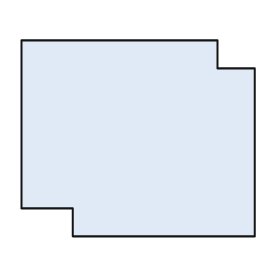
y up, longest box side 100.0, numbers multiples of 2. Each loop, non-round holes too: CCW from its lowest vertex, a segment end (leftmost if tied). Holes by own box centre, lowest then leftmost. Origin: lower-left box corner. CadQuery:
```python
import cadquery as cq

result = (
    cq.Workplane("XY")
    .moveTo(22.0, 0.0)
    .lineTo(100.0, 0.0)
    .lineTo(100.0, 72.0)
    .lineTo(84.0, 72.0)
    .lineTo(84.0, 84.0)
    .lineTo(0.0, 84.0)
    .lineTo(0.0, 12.0)
    .lineTo(22.0, 12.0)
    .close()
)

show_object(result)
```